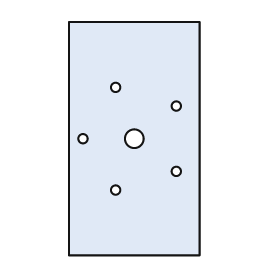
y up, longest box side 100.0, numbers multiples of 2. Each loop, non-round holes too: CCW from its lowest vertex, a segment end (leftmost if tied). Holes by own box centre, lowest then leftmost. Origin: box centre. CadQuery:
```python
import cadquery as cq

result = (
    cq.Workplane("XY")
    .moveTo(-28.0, -50.0)
    .lineTo(28.0, -50.0)
    .lineTo(28.0, 50.0)
    .lineTo(-28.0, 50.0)
    .close()
    .moveTo(-8.0, -22.0)
    .circle(2.0)
    .moveTo(18.0, -14.0)
    .circle(2.0)
    .moveTo(-22.0, 0.0)
    .circle(2.0)
    .moveTo(0.0, 0.0)
    .circle(4.0)
    .moveTo(18.0, 14.0)
    .circle(2.0)
    .moveTo(-8.0, 22.0)
    .circle(2.0)
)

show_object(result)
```